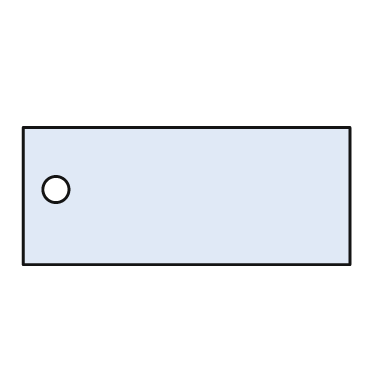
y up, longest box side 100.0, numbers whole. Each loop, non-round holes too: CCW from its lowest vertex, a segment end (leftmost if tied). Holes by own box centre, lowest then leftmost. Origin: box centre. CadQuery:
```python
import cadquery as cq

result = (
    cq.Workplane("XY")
    .moveTo(-50.0, -21.0)
    .lineTo(50.0, -21.0)
    .lineTo(50.0, 21.0)
    .lineTo(-50.0, 21.0)
    .close()
    .moveTo(-40.0, 2.0)
    .circle(4.0)
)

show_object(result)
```